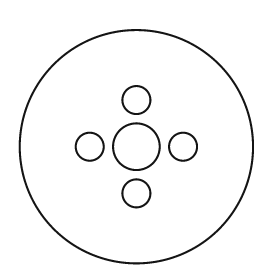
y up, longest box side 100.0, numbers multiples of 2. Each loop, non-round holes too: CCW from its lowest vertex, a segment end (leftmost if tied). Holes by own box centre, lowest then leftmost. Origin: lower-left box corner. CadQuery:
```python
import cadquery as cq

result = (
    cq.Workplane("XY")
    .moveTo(50.0, 50.0)
    .circle(50.0)
    .moveTo(50.0, 30.0)
    .circle(6.0)
    .moveTo(30.0, 50.0)
    .circle(6.0)
    .moveTo(50.0, 50.0)
    .circle(10.0)
    .moveTo(70.0, 50.0)
    .circle(6.0)
    .moveTo(50.0, 70.0)
    .circle(6.0)
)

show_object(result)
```